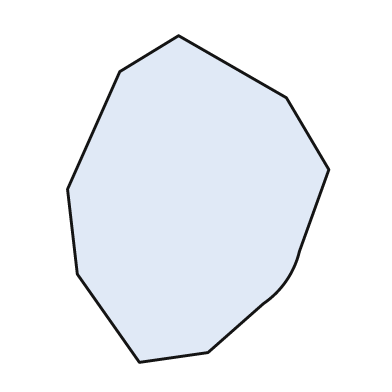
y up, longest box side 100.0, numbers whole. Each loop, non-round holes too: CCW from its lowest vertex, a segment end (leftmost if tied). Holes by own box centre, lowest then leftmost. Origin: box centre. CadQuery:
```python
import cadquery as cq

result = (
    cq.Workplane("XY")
    .moveTo(-18.0, -50.0)
    .lineTo(3.0, -47.0)
    .lineTo(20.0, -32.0)
    .threePointArc((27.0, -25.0), (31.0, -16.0))
    .lineTo(40.0, 9.0)
    .lineTo(27.0, 31.0)
    .lineTo(-6.0, 50.0)
    .lineTo(-24.0, 39.0)
    .lineTo(-40.0, 3.0)
    .lineTo(-37.0, -23.0)
    .close()
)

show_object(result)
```